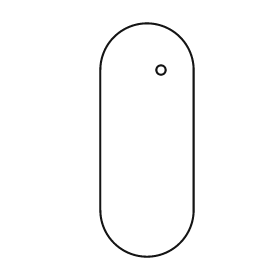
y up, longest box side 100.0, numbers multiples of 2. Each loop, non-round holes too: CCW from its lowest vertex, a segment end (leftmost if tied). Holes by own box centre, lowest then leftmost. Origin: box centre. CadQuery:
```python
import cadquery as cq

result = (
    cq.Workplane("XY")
    .moveTo(-20.0, -30.0)
    .threePointArc((0.0, -50.0), (20.0, -30.0))
    .lineTo(20.0, 30.0)
    .threePointArc((0.0, 50.0), (-20.0, 30.0))
    .close()
    .moveTo(6.0, 30.0)
    .circle(2.0)
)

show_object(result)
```